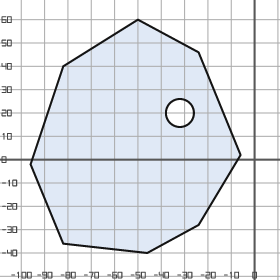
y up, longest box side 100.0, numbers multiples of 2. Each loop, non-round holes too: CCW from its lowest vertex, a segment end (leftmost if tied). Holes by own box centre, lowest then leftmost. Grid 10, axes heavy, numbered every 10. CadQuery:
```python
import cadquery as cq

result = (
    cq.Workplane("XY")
    .moveTo(-46.0, -40.0)
    .lineTo(-24.0, -28.0)
    .lineTo(-6.0, 2.0)
    .lineTo(-24.0, 46.0)
    .lineTo(-50.0, 60.0)
    .lineTo(-82.0, 40.0)
    .lineTo(-96.0, -2.0)
    .lineTo(-82.0, -36.0)
    .close()
    .moveTo(-32.0, 20.0)
    .circle(6.0)
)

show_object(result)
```